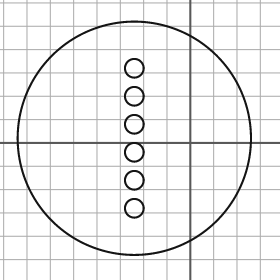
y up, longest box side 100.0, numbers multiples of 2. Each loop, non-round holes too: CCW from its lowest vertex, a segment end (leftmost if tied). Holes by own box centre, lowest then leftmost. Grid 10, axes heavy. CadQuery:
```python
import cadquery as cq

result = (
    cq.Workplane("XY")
    .moveTo(-24.0, 2.0)
    .circle(50.0)
    .moveTo(-24.0, -28.0)
    .circle(4.0)
    .moveTo(-24.0, -16.0)
    .circle(4.0)
    .moveTo(-24.0, -4.0)
    .circle(4.0)
    .moveTo(-24.0, 8.0)
    .circle(4.0)
    .moveTo(-24.0, 20.0)
    .circle(4.0)
    .moveTo(-24.0, 32.0)
    .circle(4.0)
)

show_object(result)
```